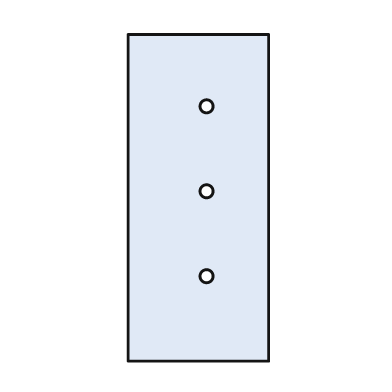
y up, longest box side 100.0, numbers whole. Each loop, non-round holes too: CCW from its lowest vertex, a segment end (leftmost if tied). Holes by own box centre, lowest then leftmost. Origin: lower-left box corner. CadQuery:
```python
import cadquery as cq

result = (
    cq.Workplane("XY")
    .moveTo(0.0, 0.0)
    .lineTo(43.0, 0.0)
    .lineTo(43.0, 100.0)
    .lineTo(0.0, 100.0)
    .close()
    .moveTo(24.0, 26.0)
    .circle(2.0)
    .moveTo(24.0, 52.0)
    .circle(2.0)
    .moveTo(24.0, 78.0)
    .circle(2.0)
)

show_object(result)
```